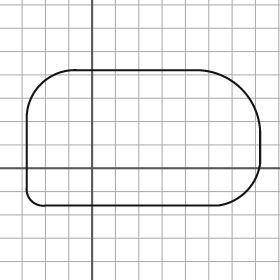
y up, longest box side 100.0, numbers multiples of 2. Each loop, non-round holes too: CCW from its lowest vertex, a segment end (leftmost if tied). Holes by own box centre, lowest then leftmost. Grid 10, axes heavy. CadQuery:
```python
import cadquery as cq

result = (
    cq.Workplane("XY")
    .moveTo(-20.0, -16.0)
    .lineTo(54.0, -16.0)
    .threePointArc((66.0, -10.0), (72.0, 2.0))
    .lineTo(72.0, 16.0)
    .threePointArc((64.0, 34.0), (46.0, 42.0))
    .lineTo(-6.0, 42.0)
    .threePointArc((-22.0, 36.0), (-28.0, 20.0))
    .lineTo(-28.0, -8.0)
    .threePointArc((-26.0, -14.0), (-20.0, -16.0))
    .close()
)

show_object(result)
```